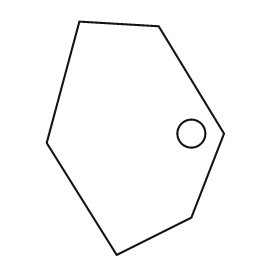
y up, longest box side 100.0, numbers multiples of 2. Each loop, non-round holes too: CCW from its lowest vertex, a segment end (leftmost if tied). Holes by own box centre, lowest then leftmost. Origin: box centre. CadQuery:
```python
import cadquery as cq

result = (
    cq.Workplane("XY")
    .moveTo(-8.0, -50.0)
    .lineTo(24.0, -34.0)
    .lineTo(38.0, 2.0)
    .lineTo(10.0, 48.0)
    .lineTo(-24.0, 50.0)
    .lineTo(-38.0, -2.0)
    .close()
    .moveTo(24.0, 2.0)
    .circle(6.0)
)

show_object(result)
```